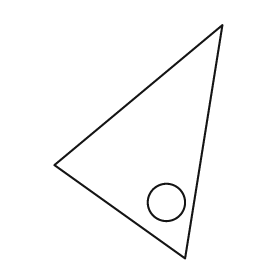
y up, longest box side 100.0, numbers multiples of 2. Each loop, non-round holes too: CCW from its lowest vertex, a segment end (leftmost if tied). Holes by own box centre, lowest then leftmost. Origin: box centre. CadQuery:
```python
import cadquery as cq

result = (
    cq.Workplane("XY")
    .moveTo(20.0, -50.0)
    .lineTo(36.0, 50.0)
    .lineTo(-36.0, -10.0)
    .close()
    .moveTo(12.0, -26.0)
    .circle(8.0)
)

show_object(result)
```